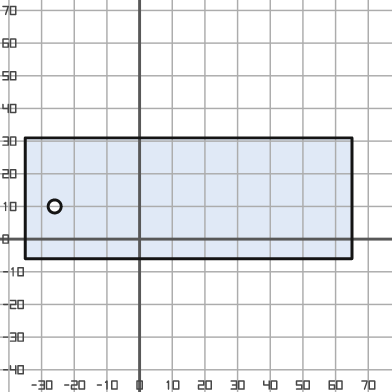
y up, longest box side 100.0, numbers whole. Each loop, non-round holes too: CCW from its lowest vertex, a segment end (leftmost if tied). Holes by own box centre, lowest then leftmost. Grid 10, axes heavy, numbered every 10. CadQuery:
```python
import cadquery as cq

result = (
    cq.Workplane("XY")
    .moveTo(-35.0, -6.0)
    .lineTo(65.0, -6.0)
    .lineTo(65.0, 31.0)
    .lineTo(-35.0, 31.0)
    .close()
    .moveTo(-26.0, 10.0)
    .circle(2.0)
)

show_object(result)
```